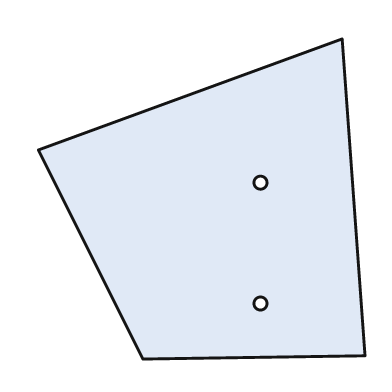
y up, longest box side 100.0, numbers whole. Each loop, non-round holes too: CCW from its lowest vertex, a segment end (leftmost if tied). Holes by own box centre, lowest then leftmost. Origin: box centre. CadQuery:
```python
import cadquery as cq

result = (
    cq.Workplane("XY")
    .moveTo(-18.0, -49.0)
    .lineTo(50.0, -48.0)
    .lineTo(43.0, 49.0)
    .lineTo(-50.0, 15.0)
    .close()
    .moveTo(18.0, -32.0)
    .circle(2.0)
    .moveTo(18.0, 5.0)
    .circle(2.0)
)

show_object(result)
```